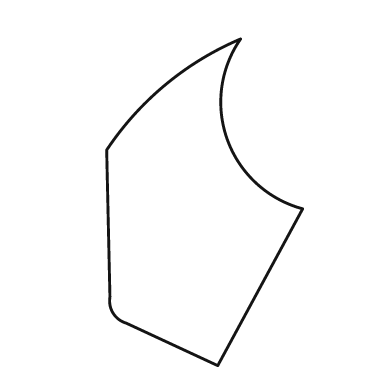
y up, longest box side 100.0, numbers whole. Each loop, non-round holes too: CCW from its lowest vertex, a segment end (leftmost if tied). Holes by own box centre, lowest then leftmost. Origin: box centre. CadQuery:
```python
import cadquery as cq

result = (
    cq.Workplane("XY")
    .moveTo(4.0, -50.0)
    .lineTo(30.0, -2.0)
    .threePointArc((7.0, 19.0), (11.0, 50.0))
    .threePointArc((-12.0, 36.0), (-30.0, 16.0))
    .lineTo(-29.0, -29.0)
    .threePointArc((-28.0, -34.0), (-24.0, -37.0))
    .close()
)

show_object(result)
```